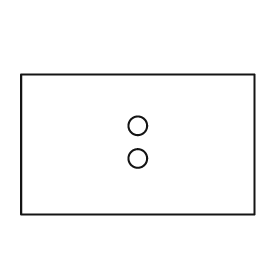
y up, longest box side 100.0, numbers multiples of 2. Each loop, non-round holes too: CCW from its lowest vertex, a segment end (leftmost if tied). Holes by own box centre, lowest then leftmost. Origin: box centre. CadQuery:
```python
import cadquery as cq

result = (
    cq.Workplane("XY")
    .moveTo(-50.0, -30.0)
    .lineTo(50.0, -30.0)
    .lineTo(50.0, 30.0)
    .lineTo(-50.0, 30.0)
    .close()
    .moveTo(0.0, -6.0)
    .circle(4.0)
    .moveTo(0.0, 8.0)
    .circle(4.0)
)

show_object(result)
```